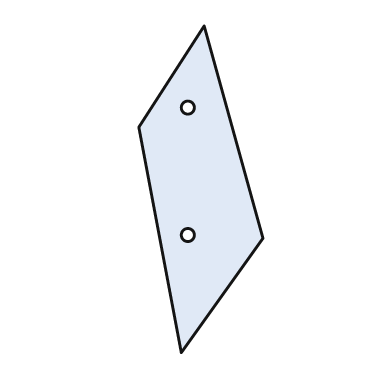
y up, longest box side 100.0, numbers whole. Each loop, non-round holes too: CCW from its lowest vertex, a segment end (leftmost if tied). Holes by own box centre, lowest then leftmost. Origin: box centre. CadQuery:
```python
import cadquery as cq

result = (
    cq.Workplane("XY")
    .moveTo(-6.0, -50.0)
    .lineTo(19.0, -15.0)
    .lineTo(1.0, 50.0)
    .lineTo(-19.0, 19.0)
    .close()
    .moveTo(-4.0, -14.0)
    .circle(2.0)
    .moveTo(-4.0, 25.0)
    .circle(2.0)
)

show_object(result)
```